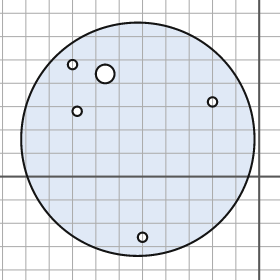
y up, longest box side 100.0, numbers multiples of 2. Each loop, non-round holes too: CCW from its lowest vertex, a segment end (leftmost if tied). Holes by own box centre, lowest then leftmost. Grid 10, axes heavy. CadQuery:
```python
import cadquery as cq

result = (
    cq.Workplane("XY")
    .moveTo(-52.0, 16.0)
    .circle(50.0)
    .moveTo(-50.0, -26.0)
    .circle(2.0)
    .moveTo(-78.0, 28.0)
    .circle(2.0)
    .moveTo(-20.0, 32.0)
    .circle(2.0)
    .moveTo(-66.0, 44.0)
    .circle(4.0)
    .moveTo(-80.0, 48.0)
    .circle(2.0)
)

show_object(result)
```